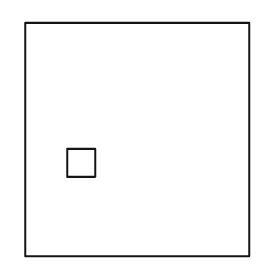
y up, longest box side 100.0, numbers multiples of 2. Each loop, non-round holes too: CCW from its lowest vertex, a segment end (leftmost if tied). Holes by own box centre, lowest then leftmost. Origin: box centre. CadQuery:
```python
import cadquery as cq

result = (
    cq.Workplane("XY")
    .moveTo(-48.0, -50.0)
    .lineTo(48.0, -50.0)
    .lineTo(48.0, 50.0)
    .lineTo(-48.0, 50.0)
    .close()
    .moveTo(-30.0, -16.0)
    .lineTo(-18.0, -16.0)
    .lineTo(-18.0, -4.0)
    .lineTo(-30.0, -4.0)
    .close()
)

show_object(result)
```